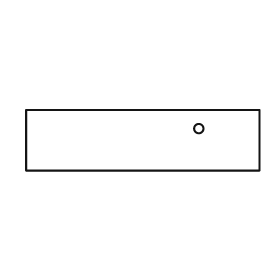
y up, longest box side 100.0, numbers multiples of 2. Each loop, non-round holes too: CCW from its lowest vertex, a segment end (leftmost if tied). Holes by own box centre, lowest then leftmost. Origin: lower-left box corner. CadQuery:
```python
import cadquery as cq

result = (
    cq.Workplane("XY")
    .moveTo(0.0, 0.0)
    .lineTo(100.0, 0.0)
    .lineTo(100.0, 26.0)
    .lineTo(0.0, 26.0)
    .close()
    .moveTo(74.0, 18.0)
    .circle(2.0)
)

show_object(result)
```